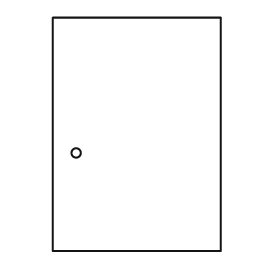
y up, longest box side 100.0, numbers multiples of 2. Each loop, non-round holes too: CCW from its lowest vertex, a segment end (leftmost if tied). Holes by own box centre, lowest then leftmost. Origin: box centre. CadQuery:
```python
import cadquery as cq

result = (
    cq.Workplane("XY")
    .moveTo(-36.0, -50.0)
    .lineTo(36.0, -50.0)
    .lineTo(36.0, 50.0)
    .lineTo(-36.0, 50.0)
    .close()
    .moveTo(-26.0, -8.0)
    .circle(2.0)
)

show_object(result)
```